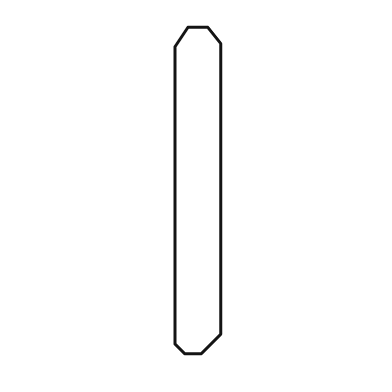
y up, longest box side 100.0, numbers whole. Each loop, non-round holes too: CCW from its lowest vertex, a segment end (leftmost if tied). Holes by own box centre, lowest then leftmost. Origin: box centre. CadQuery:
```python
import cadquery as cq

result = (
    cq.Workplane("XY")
    .moveTo(-4.0, -50.0)
    .lineTo(1.0, -50.0)
    .lineTo(7.0, -44.0)
    .lineTo(7.0, 45.0)
    .lineTo(3.0, 50.0)
    .lineTo(-3.0, 50.0)
    .lineTo(-7.0, 44.0)
    .lineTo(-7.0, -47.0)
    .close()
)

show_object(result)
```